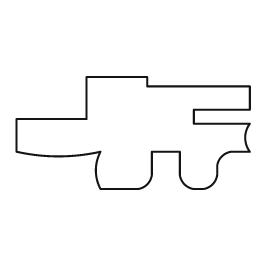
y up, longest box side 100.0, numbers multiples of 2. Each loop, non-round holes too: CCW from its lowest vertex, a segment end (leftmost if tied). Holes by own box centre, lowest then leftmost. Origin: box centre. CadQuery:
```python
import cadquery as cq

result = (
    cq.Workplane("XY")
    .moveTo(-14.0, -24.0)
    .lineTo(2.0, -24.0)
    .threePointArc((6.0, -22.0), (8.0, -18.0))
    .lineTo(8.0, -8.0)
    .lineTo(20.0, -8.0)
    .lineTo(20.0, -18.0)
    .threePointArc((22.0, -22.0), (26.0, -24.0))
    .lineTo(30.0, -24.0)
    .threePointArc((34.0, -22.0), (36.0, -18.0))
    .lineTo(36.0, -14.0)
    .threePointArc((38.0, -10.0), (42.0, -8.0))
    .lineTo(50.0, -8.0)
    .threePointArc((48.0, -2.0), (50.0, 4.0))
    .lineTo(26.0, 4.0)
    .lineTo(26.0, 10.0)
    .lineTo(50.0, 10.0)
    .lineTo(50.0, 20.0)
    .lineTo(6.0, 20.0)
    .lineTo(6.0, 24.0)
    .lineTo(-20.0, 24.0)
    .lineTo(-20.0, 6.0)
    .lineTo(-50.0, 6.0)
    .lineTo(-50.0, -8.0)
    .threePointArc((-32.0, -10.0), (-14.0, -8.0))
    .threePointArc((-16.0, -16.0), (-14.0, -24.0))
    .close()
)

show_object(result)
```